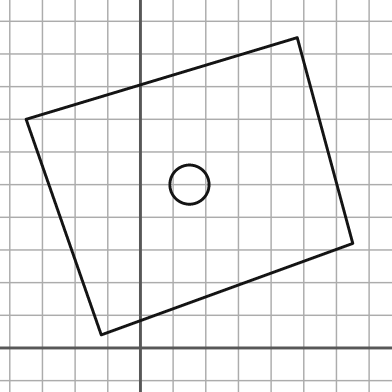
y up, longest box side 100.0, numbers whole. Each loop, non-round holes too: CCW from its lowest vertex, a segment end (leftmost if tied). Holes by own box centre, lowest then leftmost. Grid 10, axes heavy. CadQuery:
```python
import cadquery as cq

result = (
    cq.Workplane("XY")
    .moveTo(-12.0, 4.0)
    .lineTo(65.0, 32.0)
    .lineTo(48.0, 95.0)
    .lineTo(-35.0, 70.0)
    .close()
    .moveTo(15.0, 50.0)
    .circle(6.0)
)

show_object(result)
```